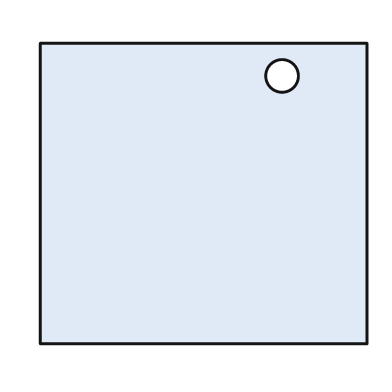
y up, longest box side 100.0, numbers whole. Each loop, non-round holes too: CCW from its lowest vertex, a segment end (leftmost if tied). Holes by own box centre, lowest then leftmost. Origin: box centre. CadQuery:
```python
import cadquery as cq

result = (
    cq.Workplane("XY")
    .moveTo(-50.0, -46.0)
    .lineTo(50.0, -46.0)
    .lineTo(50.0, 46.0)
    .lineTo(-50.0, 46.0)
    .close()
    .moveTo(24.0, 36.0)
    .circle(5.0)
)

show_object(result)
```